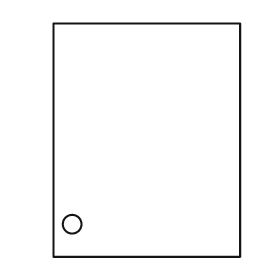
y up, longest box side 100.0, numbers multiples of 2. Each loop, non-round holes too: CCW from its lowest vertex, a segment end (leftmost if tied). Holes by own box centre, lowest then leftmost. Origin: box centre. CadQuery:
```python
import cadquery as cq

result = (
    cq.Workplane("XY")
    .moveTo(-40.0, -50.0)
    .lineTo(40.0, -50.0)
    .lineTo(40.0, 50.0)
    .lineTo(-40.0, 50.0)
    .close()
    .moveTo(-32.0, -36.0)
    .circle(4.0)
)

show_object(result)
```